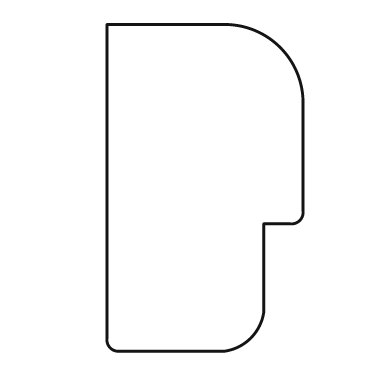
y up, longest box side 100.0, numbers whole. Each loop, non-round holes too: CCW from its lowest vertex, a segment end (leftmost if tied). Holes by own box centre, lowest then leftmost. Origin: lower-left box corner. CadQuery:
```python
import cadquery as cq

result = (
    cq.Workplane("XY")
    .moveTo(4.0, 0.0)
    .lineTo(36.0, 0.0)
    .threePointArc((44.0, 4.0), (48.0, 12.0))
    .lineTo(48.0, 39.0)
    .lineTo(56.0, 39.0)
    .threePointArc((59.0, 40.0), (60.0, 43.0))
    .lineTo(60.0, 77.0)
    .threePointArc((53.0, 93.0), (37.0, 100.0))
    .lineTo(0.0, 100.0)
    .lineTo(0.0, 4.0)
    .threePointArc((1.0, 1.0), (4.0, 0.0))
    .close()
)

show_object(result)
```